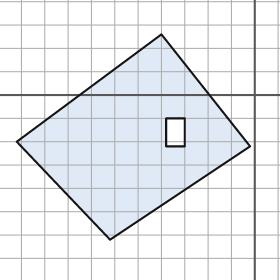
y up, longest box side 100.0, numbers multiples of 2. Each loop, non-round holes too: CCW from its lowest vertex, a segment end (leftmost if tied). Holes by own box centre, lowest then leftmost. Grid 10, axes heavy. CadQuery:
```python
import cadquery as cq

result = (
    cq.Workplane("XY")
    .moveTo(-62.0, -62.0)
    .lineTo(-2.0, -22.0)
    .lineTo(-40.0, 26.0)
    .lineTo(-102.0, -20.0)
    .close()
    .moveTo(-38.0, -22.0)
    .lineTo(-30.0, -22.0)
    .lineTo(-30.0, -10.0)
    .lineTo(-38.0, -10.0)
    .close()
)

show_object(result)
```